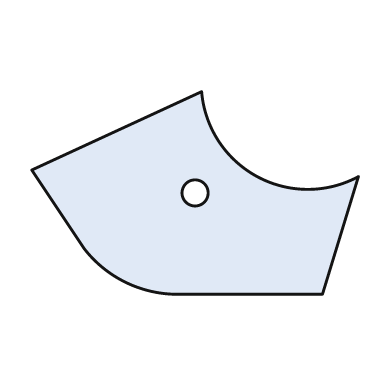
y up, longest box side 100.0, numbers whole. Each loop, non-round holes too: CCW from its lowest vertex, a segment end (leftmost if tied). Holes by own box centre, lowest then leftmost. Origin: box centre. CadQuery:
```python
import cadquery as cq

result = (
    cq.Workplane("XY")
    .moveTo(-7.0, -31.0)
    .lineTo(39.0, -31.0)
    .lineTo(50.0, 5.0)
    .threePointArc((19.0, 5.0), (2.0, 31.0))
    .lineTo(-50.0, 7.0)
    .lineTo(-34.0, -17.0)
    .threePointArc((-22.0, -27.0), (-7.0, -31.0))
    .close()
    .moveTo(0.0, 0.0)
    .circle(4.0)
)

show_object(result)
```